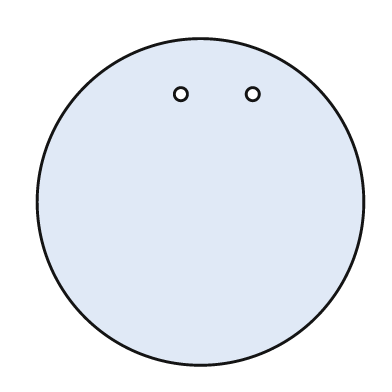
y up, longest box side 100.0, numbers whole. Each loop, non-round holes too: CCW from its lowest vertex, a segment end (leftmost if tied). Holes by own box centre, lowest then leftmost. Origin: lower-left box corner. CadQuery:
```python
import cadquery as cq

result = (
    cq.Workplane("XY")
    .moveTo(50.0, 50.0)
    .circle(50.0)
    .moveTo(44.0, 83.0)
    .circle(2.0)
    .moveTo(66.0, 83.0)
    .circle(2.0)
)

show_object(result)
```